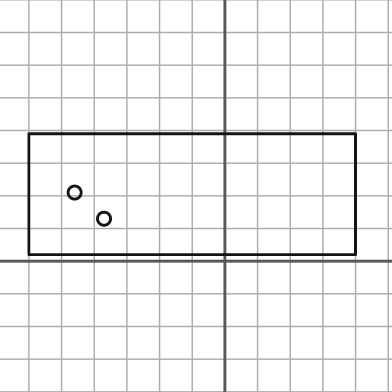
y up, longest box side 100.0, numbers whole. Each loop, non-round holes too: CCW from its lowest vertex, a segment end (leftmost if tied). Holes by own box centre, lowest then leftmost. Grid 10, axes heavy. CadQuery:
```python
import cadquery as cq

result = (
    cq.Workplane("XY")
    .moveTo(-60.0, 2.0)
    .lineTo(40.0, 2.0)
    .lineTo(40.0, 39.0)
    .lineTo(-60.0, 39.0)
    .close()
    .moveTo(-37.0, 13.0)
    .circle(2.0)
    .moveTo(-46.0, 21.0)
    .circle(2.0)
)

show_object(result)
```